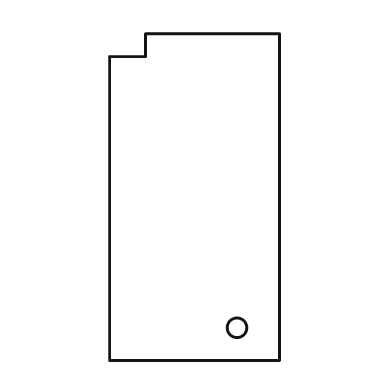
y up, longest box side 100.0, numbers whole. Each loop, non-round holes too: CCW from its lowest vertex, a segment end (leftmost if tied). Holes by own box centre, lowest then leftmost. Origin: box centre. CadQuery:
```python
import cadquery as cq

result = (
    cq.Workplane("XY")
    .moveTo(-26.0, -50.0)
    .lineTo(26.0, -50.0)
    .lineTo(26.0, 50.0)
    .lineTo(-15.0, 50.0)
    .lineTo(-15.0, 43.0)
    .lineTo(-26.0, 43.0)
    .close()
    .moveTo(13.0, -40.0)
    .circle(3.0)
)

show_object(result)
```